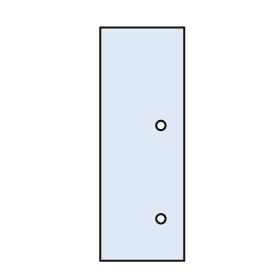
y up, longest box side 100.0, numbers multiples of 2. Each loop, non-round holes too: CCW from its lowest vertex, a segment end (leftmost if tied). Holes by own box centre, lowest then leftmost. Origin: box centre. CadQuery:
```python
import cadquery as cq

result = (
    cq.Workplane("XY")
    .moveTo(-18.0, -50.0)
    .lineTo(18.0, -50.0)
    .lineTo(18.0, 50.0)
    .lineTo(-18.0, 50.0)
    .close()
    .moveTo(8.0, -32.0)
    .circle(2.0)
    .moveTo(8.0, 8.0)
    .circle(2.0)
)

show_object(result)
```